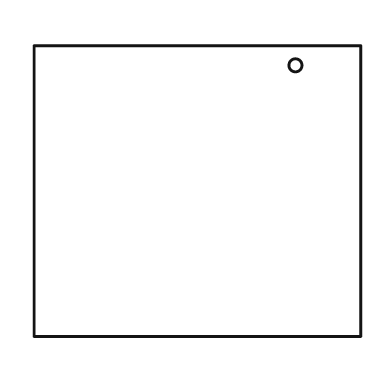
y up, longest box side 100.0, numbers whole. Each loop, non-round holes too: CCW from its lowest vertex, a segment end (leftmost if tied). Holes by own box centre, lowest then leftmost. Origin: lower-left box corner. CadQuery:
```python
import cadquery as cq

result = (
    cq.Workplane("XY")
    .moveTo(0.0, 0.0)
    .lineTo(100.0, 0.0)
    .lineTo(100.0, 89.0)
    .lineTo(0.0, 89.0)
    .close()
    .moveTo(80.0, 83.0)
    .circle(2.0)
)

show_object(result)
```